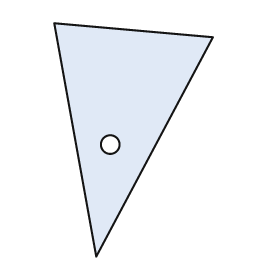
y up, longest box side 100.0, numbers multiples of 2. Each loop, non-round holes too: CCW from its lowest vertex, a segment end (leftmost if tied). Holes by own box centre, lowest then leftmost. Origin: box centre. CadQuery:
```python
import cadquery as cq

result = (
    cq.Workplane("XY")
    .moveTo(-16.0, -50.0)
    .lineTo(34.0, 44.0)
    .lineTo(-34.0, 50.0)
    .close()
    .moveTo(-10.0, -2.0)
    .circle(4.0)
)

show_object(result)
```